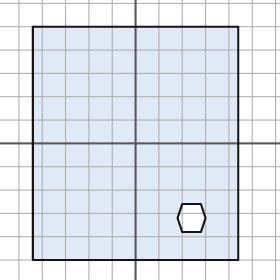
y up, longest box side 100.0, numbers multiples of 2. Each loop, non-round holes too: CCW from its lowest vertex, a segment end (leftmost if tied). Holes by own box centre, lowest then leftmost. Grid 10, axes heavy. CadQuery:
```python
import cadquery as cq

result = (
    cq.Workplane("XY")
    .moveTo(-44.0, -50.0)
    .lineTo(44.0, -50.0)
    .lineTo(44.0, 50.0)
    .lineTo(-44.0, 50.0)
    .close()
    .moveTo(20.0, -38.0)
    .lineTo(28.0, -38.0)
    .lineTo(30.0, -32.0)
    .lineTo(28.0, -26.0)
    .lineTo(20.0, -26.0)
    .lineTo(18.0, -32.0)
    .close()
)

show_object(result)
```